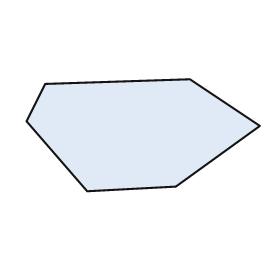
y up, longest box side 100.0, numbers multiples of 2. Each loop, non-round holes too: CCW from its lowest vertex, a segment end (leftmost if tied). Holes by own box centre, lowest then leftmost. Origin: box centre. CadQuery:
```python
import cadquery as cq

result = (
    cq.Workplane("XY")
    .moveTo(-24.0, -24.0)
    .lineTo(14.0, -22.0)
    .lineTo(50.0, 4.0)
    .lineTo(20.0, 24.0)
    .lineTo(-42.0, 22.0)
    .lineTo(-50.0, 6.0)
    .close()
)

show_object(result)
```